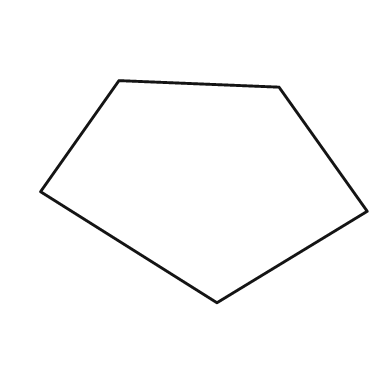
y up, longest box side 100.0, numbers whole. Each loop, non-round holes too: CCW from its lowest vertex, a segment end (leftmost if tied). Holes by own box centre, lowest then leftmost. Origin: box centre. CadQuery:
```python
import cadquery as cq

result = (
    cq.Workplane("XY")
    .moveTo(4.0, -34.0)
    .lineTo(50.0, -6.0)
    .lineTo(23.0, 32.0)
    .lineTo(-26.0, 34.0)
    .lineTo(-50.0, 0.0)
    .close()
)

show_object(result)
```